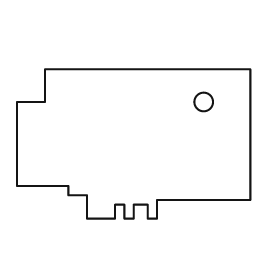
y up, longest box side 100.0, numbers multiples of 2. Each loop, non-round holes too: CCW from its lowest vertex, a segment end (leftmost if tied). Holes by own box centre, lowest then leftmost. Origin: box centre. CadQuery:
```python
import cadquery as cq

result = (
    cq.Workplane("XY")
    .moveTo(-20.0, -32.0)
    .lineTo(-8.0, -32.0)
    .lineTo(-8.0, -26.0)
    .lineTo(-4.0, -26.0)
    .lineTo(-4.0, -32.0)
    .lineTo(0.0, -32.0)
    .lineTo(0.0, -26.0)
    .lineTo(6.0, -26.0)
    .lineTo(6.0, -32.0)
    .lineTo(10.0, -32.0)
    .lineTo(10.0, -24.0)
    .lineTo(50.0, -24.0)
    .lineTo(50.0, 32.0)
    .lineTo(-38.0, 32.0)
    .lineTo(-38.0, 18.0)
    .lineTo(-50.0, 18.0)
    .lineTo(-50.0, -18.0)
    .lineTo(-28.0, -18.0)
    .lineTo(-28.0, -22.0)
    .lineTo(-20.0, -22.0)
    .close()
    .moveTo(30.0, 18.0)
    .circle(4.0)
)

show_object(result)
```